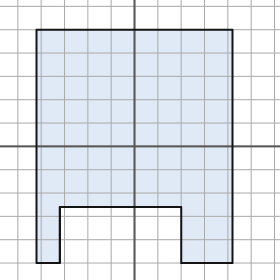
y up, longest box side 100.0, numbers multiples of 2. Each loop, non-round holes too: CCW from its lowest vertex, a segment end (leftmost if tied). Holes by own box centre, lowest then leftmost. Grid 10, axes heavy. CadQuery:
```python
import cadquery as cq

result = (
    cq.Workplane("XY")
    .moveTo(-42.0, -50.0)
    .lineTo(-32.0, -50.0)
    .lineTo(-32.0, -26.0)
    .lineTo(20.0, -26.0)
    .lineTo(20.0, -50.0)
    .lineTo(42.0, -50.0)
    .lineTo(42.0, 50.0)
    .lineTo(-42.0, 50.0)
    .close()
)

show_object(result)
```